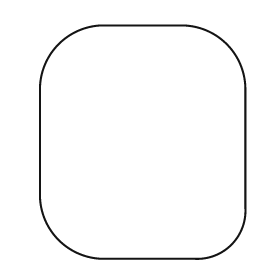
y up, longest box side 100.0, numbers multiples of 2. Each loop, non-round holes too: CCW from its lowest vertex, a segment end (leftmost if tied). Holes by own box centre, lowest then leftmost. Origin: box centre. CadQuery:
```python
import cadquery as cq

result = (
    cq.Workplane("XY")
    .moveTo(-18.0, -50.0)
    .lineTo(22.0, -50.0)
    .threePointArc((38.0, -44.0), (44.0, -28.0))
    .lineTo(44.0, 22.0)
    .threePointArc((36.0, 42.0), (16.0, 50.0))
    .lineTo(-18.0, 50.0)
    .threePointArc((-36.0, 42.0), (-44.0, 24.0))
    .lineTo(-44.0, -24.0)
    .threePointArc((-36.0, -42.0), (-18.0, -50.0))
    .close()
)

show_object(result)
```